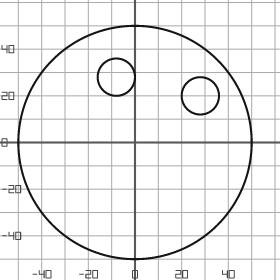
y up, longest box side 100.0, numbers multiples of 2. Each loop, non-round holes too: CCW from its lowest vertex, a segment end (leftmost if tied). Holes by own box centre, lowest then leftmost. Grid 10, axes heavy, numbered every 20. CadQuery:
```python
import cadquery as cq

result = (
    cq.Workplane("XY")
    .moveTo(0.0, 0.0)
    .circle(50.0)
    .moveTo(28.0, 20.0)
    .circle(8.0)
    .moveTo(-8.0, 28.0)
    .circle(8.0)
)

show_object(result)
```